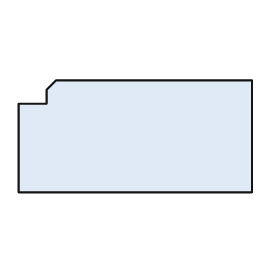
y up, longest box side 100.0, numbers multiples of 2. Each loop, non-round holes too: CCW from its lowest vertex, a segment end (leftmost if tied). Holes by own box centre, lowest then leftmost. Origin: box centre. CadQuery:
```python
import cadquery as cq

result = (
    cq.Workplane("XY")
    .moveTo(-50.0, -24.0)
    .lineTo(50.0, -24.0)
    .lineTo(50.0, 24.0)
    .lineTo(-34.0, 24.0)
    .lineTo(-38.0, 20.0)
    .lineTo(-38.0, 14.0)
    .lineTo(-50.0, 14.0)
    .close()
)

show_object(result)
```